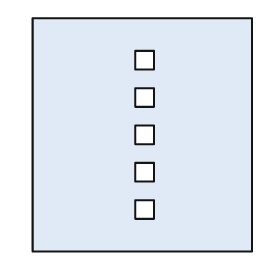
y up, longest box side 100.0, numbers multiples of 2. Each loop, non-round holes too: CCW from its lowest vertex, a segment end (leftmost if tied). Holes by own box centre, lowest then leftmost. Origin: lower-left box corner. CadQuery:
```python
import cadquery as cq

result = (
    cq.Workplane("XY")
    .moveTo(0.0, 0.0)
    .lineTo(94.0, 0.0)
    .lineTo(94.0, 100.0)
    .lineTo(0.0, 100.0)
    .close()
    .moveTo(44.0, 14.0)
    .lineTo(52.0, 14.0)
    .lineTo(52.0, 22.0)
    .lineTo(44.0, 22.0)
    .close()
    .moveTo(44.0, 30.0)
    .lineTo(52.0, 30.0)
    .lineTo(52.0, 38.0)
    .lineTo(44.0, 38.0)
    .close()
    .moveTo(44.0, 46.0)
    .lineTo(52.0, 46.0)
    .lineTo(52.0, 54.0)
    .lineTo(44.0, 54.0)
    .close()
    .moveTo(44.0, 62.0)
    .lineTo(52.0, 62.0)
    .lineTo(52.0, 70.0)
    .lineTo(44.0, 70.0)
    .close()
    .moveTo(44.0, 78.0)
    .lineTo(52.0, 78.0)
    .lineTo(52.0, 86.0)
    .lineTo(44.0, 86.0)
    .close()
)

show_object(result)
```